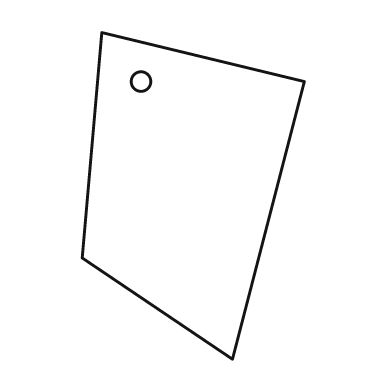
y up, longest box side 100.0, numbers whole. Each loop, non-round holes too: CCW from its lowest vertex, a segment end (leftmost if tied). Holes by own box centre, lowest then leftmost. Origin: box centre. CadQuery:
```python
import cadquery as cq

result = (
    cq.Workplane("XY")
    .moveTo(12.0, -50.0)
    .lineTo(34.0, 35.0)
    .lineTo(-28.0, 50.0)
    .lineTo(-34.0, -19.0)
    .close()
    .moveTo(-16.0, 35.0)
    .circle(3.0)
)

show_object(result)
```